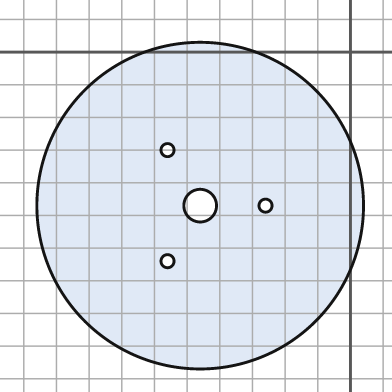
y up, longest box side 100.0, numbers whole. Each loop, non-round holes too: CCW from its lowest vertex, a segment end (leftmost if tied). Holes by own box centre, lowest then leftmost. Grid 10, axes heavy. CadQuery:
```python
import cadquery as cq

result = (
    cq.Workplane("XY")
    .moveTo(-46.0, -47.0)
    .circle(50.0)
    .moveTo(-56.0, -64.0)
    .circle(2.0)
    .moveTo(-46.0, -47.0)
    .circle(5.0)
    .moveTo(-26.0, -47.0)
    .circle(2.0)
    .moveTo(-56.0, -30.0)
    .circle(2.0)
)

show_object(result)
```